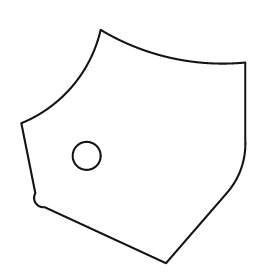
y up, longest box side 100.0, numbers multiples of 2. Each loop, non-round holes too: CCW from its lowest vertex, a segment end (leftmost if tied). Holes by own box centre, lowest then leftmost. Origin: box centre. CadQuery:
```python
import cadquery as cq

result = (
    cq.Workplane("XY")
    .moveTo(14.0, -50.0)
    .lineTo(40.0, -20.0)
    .threePointArc((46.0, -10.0), (48.0, 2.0))
    .lineTo(48.0, 36.0)
    .threePointArc((16.0, 38.0), (-14.0, 50.0))
    .threePointArc((-26.0, 26.0), (-48.0, 10.0))
    .lineTo(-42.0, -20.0)
    .threePointArc((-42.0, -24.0), (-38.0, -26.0))
    .close()
    .moveTo(-20.0, -4.0)
    .circle(6.0)
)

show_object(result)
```